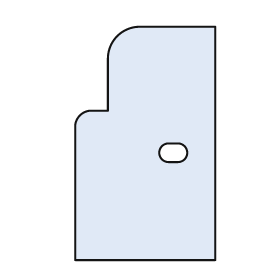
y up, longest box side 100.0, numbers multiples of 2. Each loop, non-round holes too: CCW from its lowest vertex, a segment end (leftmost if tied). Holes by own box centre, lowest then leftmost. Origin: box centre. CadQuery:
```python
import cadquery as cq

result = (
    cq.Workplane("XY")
    .moveTo(-30.0, -50.0)
    .lineTo(30.0, -50.0)
    .lineTo(30.0, 50.0)
    .lineTo(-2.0, 50.0)
    .threePointArc((-12.0, 46.0), (-16.0, 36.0))
    .lineTo(-16.0, 14.0)
    .lineTo(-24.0, 14.0)
    .threePointArc((-28.0, 12.0), (-30.0, 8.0))
    .close()
    .moveTo(10.0, -8.0)
    .lineTo(14.0, -8.0)
    .threePointArc((18.0, -4.0), (14.0, 0.0))
    .lineTo(10.0, 0.0)
    .threePointArc((6.0, -4.0), (10.0, -8.0))
    .close()
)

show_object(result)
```